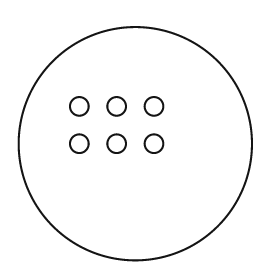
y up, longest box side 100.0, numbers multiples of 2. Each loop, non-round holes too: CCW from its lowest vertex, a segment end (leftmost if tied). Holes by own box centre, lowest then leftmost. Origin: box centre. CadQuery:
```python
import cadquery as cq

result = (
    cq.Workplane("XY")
    .moveTo(0.0, 0.0)
    .circle(50.0)
    .moveTo(-24.0, 0.0)
    .circle(4.0)
    .moveTo(-8.0, 0.0)
    .circle(4.0)
    .moveTo(8.0, 0.0)
    .circle(4.0)
    .moveTo(-24.0, 16.0)
    .circle(4.0)
    .moveTo(-8.0, 16.0)
    .circle(4.0)
    .moveTo(8.0, 16.0)
    .circle(4.0)
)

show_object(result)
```